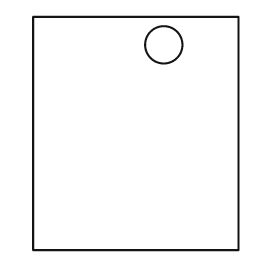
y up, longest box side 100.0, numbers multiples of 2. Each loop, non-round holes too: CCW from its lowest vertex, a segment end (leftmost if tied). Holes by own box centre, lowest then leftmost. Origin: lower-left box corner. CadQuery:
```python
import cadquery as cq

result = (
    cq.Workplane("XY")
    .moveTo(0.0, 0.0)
    .lineTo(88.0, 0.0)
    .lineTo(88.0, 100.0)
    .lineTo(0.0, 100.0)
    .close()
    .moveTo(56.0, 88.0)
    .circle(8.0)
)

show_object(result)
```